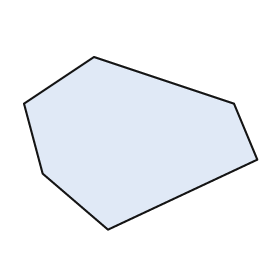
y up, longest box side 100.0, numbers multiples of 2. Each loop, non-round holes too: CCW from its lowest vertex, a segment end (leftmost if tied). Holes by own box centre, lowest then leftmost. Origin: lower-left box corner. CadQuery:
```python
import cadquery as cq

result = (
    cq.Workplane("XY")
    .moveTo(36.0, 0.0)
    .lineTo(100.0, 30.0)
    .lineTo(90.0, 54.0)
    .lineTo(30.0, 74.0)
    .lineTo(0.0, 54.0)
    .lineTo(8.0, 24.0)
    .close()
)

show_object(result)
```